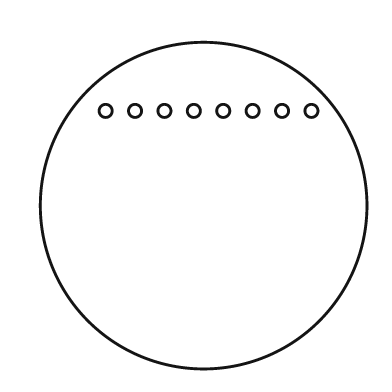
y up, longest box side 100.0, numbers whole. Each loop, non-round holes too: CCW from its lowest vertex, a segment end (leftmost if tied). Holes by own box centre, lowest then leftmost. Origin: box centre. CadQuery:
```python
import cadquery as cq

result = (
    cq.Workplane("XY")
    .moveTo(0.0, 0.0)
    .circle(50.0)
    .moveTo(-30.0, 29.0)
    .circle(2.0)
    .moveTo(-21.0, 29.0)
    .circle(2.0)
    .moveTo(-12.0, 29.0)
    .circle(2.0)
    .moveTo(-3.0, 29.0)
    .circle(2.0)
    .moveTo(6.0, 29.0)
    .circle(2.0)
    .moveTo(15.0, 29.0)
    .circle(2.0)
    .moveTo(24.0, 29.0)
    .circle(2.0)
    .moveTo(33.0, 29.0)
    .circle(2.0)
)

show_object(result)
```